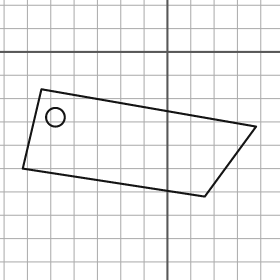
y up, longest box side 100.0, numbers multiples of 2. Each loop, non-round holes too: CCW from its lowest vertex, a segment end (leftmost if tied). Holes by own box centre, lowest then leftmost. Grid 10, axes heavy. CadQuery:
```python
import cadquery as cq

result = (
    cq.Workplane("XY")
    .moveTo(16.0, -62.0)
    .lineTo(38.0, -32.0)
    .lineTo(-54.0, -16.0)
    .lineTo(-62.0, -50.0)
    .close()
    .moveTo(-48.0, -28.0)
    .circle(4.0)
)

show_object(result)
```